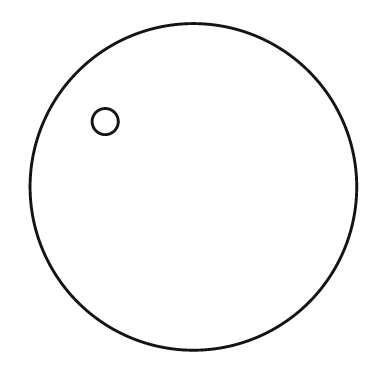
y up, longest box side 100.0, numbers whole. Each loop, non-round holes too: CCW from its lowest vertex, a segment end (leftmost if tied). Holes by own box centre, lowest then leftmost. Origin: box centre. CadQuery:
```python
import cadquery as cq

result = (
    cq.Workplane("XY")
    .moveTo(0.0, 0.0)
    .circle(50.0)
    .moveTo(-27.0, 20.0)
    .circle(4.0)
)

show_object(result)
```